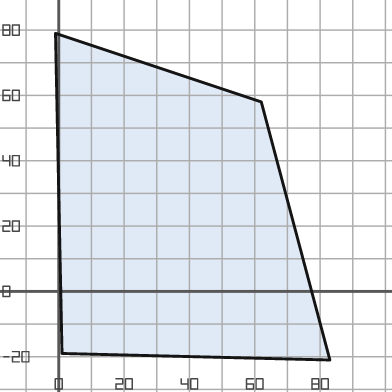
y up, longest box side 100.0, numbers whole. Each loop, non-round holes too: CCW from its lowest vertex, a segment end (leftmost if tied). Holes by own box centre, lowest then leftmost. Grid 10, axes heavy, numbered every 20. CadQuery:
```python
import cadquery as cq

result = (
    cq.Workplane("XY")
    .moveTo(83.0, -21.0)
    .lineTo(62.0, 58.0)
    .lineTo(-1.0, 79.0)
    .lineTo(1.0, -19.0)
    .close()
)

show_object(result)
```